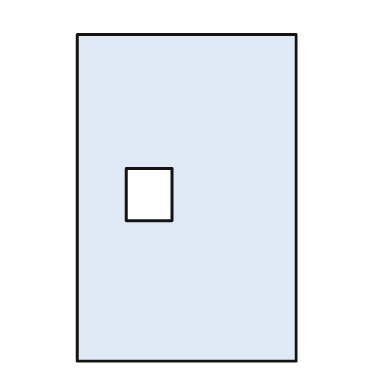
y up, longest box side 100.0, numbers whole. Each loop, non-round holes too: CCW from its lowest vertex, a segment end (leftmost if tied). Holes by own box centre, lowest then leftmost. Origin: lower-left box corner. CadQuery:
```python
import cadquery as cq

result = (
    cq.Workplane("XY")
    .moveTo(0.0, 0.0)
    .lineTo(67.0, 0.0)
    .lineTo(67.0, 100.0)
    .lineTo(0.0, 100.0)
    .close()
    .moveTo(15.0, 43.0)
    .lineTo(29.0, 43.0)
    .lineTo(29.0, 59.0)
    .lineTo(15.0, 59.0)
    .close()
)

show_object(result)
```